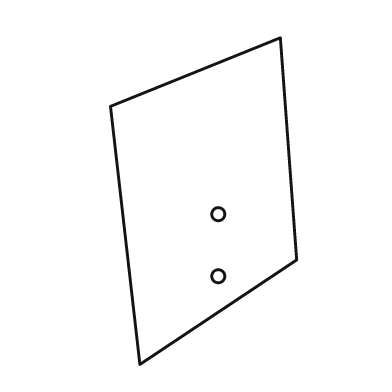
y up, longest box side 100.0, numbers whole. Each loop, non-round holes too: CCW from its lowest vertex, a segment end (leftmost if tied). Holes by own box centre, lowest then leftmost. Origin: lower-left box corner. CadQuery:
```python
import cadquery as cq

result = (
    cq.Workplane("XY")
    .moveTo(9.0, 0.0)
    .lineTo(57.0, 32.0)
    .lineTo(52.0, 100.0)
    .lineTo(0.0, 79.0)
    .close()
    .moveTo(33.0, 27.0)
    .circle(2.0)
    .moveTo(33.0, 46.0)
    .circle(2.0)
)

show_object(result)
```